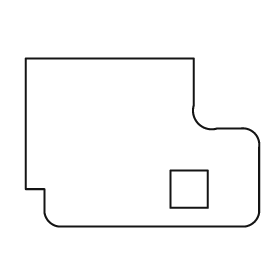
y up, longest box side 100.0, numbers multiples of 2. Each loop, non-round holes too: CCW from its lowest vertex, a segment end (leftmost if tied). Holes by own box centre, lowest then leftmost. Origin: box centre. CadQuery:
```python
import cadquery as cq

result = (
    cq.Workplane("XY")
    .moveTo(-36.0, -36.0)
    .lineTo(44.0, -36.0)
    .threePointArc((48.0, -34.0), (50.0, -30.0))
    .lineTo(50.0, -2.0)
    .threePointArc((48.0, 4.0), (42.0, 6.0))
    .lineTo(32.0, 6.0)
    .threePointArc((24.0, 8.0), (22.0, 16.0))
    .lineTo(22.0, 36.0)
    .lineTo(-50.0, 36.0)
    .lineTo(-50.0, -20.0)
    .lineTo(-42.0, -20.0)
    .lineTo(-42.0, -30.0)
    .threePointArc((-40.0, -34.0), (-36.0, -36.0))
    .close()
    .moveTo(12.0, -28.0)
    .lineTo(28.0, -28.0)
    .lineTo(28.0, -12.0)
    .lineTo(12.0, -12.0)
    .close()
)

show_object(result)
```